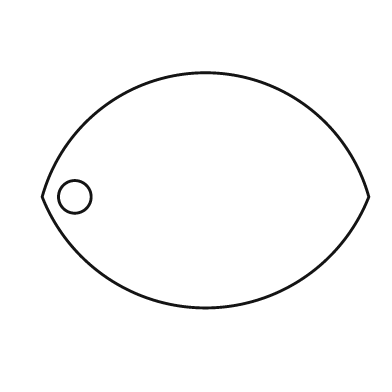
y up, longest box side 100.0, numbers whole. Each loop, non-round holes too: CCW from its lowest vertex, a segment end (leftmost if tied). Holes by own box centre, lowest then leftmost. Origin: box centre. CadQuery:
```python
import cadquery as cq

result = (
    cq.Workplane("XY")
    .moveTo(-50.0, -2.0)
    .threePointArc((0.0, -36.0), (50.0, -2.0))
    .threePointArc((0.0, 36.0), (-50.0, -2.0))
    .close()
    .moveTo(-40.0, -2.0)
    .circle(5.0)
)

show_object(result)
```